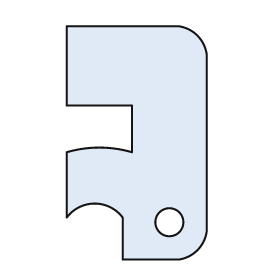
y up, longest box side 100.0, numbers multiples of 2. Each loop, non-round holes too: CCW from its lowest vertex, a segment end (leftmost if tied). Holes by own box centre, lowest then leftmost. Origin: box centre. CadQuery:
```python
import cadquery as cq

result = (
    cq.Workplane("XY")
    .moveTo(-6.0, -50.0)
    .lineTo(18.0, -50.0)
    .threePointArc((26.0, -46.0), (30.0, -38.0))
    .lineTo(30.0, 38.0)
    .threePointArc((26.0, 46.0), (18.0, 50.0))
    .lineTo(-30.0, 50.0)
    .lineTo(-30.0, 16.0)
    .lineTo(-2.0, 16.0)
    .lineTo(-2.0, -4.0)
    .threePointArc((-16.0, -2.0), (-30.0, -4.0))
    .lineTo(-30.0, -32.0)
    .threePointArc((-18.0, -26.0), (-6.0, -32.0))
    .close()
    .moveTo(14.0, -34.0)
    .circle(6.0)
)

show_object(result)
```